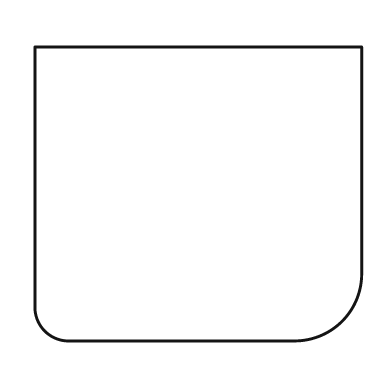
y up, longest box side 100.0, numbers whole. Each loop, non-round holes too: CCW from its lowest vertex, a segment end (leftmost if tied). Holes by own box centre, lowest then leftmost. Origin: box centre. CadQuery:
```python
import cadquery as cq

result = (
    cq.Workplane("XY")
    .moveTo(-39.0, -45.0)
    .lineTo(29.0, -45.0)
    .threePointArc((44.0, -39.0), (50.0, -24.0))
    .lineTo(50.0, 45.0)
    .lineTo(-50.0, 45.0)
    .lineTo(-50.0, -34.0)
    .threePointArc((-47.0, -42.0), (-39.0, -45.0))
    .close()
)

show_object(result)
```